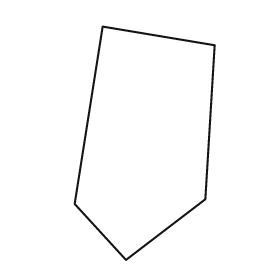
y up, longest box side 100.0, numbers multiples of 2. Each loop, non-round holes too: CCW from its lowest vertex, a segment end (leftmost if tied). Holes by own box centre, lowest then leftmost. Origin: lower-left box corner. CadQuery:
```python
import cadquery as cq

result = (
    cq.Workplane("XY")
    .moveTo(22.0, 0.0)
    .lineTo(56.0, 26.0)
    .lineTo(60.0, 92.0)
    .lineTo(12.0, 100.0)
    .lineTo(0.0, 24.0)
    .close()
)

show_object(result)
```